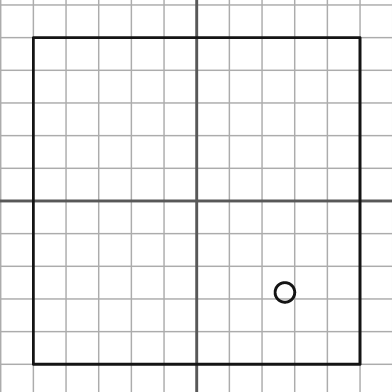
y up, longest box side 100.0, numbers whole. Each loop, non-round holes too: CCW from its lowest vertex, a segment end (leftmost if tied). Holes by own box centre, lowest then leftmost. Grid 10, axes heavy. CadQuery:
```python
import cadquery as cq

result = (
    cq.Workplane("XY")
    .moveTo(-50.0, -50.0)
    .lineTo(50.0, -50.0)
    .lineTo(50.0, 50.0)
    .lineTo(-50.0, 50.0)
    .close()
    .moveTo(27.0, -28.0)
    .circle(3.0)
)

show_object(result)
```